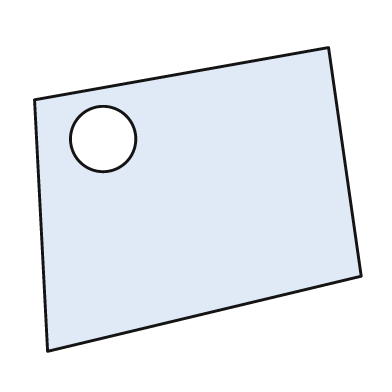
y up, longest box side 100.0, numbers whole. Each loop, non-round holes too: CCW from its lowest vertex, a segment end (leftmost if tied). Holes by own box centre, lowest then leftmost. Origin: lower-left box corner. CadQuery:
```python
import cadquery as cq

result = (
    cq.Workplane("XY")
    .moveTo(4.0, 0.0)
    .lineTo(100.0, 23.0)
    .lineTo(90.0, 93.0)
    .lineTo(0.0, 77.0)
    .close()
    .moveTo(21.0, 65.0)
    .circle(10.0)
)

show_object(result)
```